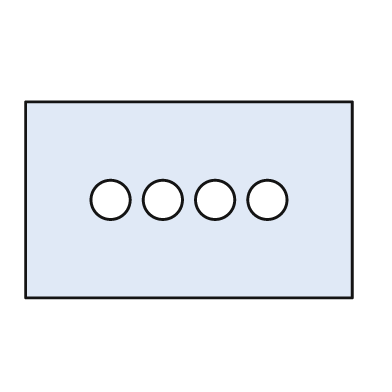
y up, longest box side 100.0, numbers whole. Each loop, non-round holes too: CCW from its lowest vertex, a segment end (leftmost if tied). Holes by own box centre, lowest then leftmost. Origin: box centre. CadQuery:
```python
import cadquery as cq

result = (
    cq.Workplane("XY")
    .moveTo(-50.0, -30.0)
    .lineTo(50.0, -30.0)
    .lineTo(50.0, 30.0)
    .lineTo(-50.0, 30.0)
    .close()
    .moveTo(-24.0, 0.0)
    .circle(6.0)
    .moveTo(-8.0, 0.0)
    .circle(6.0)
    .moveTo(8.0, 0.0)
    .circle(6.0)
    .moveTo(24.0, 0.0)
    .circle(6.0)
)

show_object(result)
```